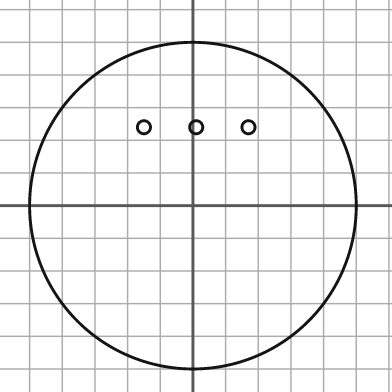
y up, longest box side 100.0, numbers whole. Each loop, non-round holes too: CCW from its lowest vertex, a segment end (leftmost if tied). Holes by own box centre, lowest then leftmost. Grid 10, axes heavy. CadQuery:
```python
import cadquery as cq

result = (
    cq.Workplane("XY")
    .moveTo(0.0, 0.0)
    .circle(50.0)
    .moveTo(-15.0, 24.0)
    .circle(2.0)
    .moveTo(1.0, 24.0)
    .circle(2.0)
    .moveTo(17.0, 24.0)
    .circle(2.0)
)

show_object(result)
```